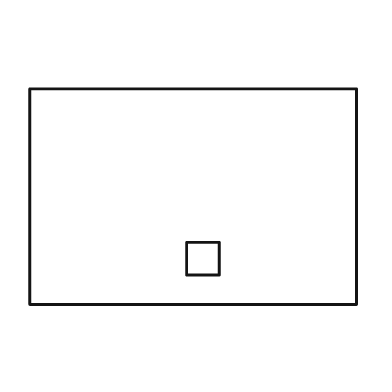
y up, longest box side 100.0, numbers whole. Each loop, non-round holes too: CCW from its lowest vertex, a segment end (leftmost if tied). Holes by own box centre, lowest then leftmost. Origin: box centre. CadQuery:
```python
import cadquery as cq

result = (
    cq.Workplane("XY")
    .moveTo(-50.0, -33.0)
    .lineTo(50.0, -33.0)
    .lineTo(50.0, 33.0)
    .lineTo(-50.0, 33.0)
    .close()
    .moveTo(-2.0, -24.0)
    .lineTo(8.0, -24.0)
    .lineTo(8.0, -14.0)
    .lineTo(-2.0, -14.0)
    .close()
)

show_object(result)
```